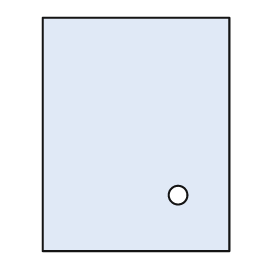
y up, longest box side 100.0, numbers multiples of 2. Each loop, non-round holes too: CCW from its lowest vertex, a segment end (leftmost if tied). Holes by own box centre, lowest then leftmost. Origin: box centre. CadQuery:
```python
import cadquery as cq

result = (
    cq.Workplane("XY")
    .moveTo(-40.0, -50.0)
    .lineTo(40.0, -50.0)
    .lineTo(40.0, 50.0)
    .lineTo(-40.0, 50.0)
    .close()
    .moveTo(18.0, -26.0)
    .circle(4.0)
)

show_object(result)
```